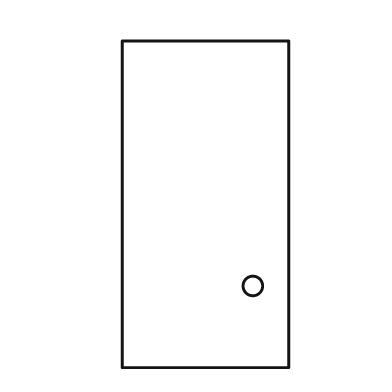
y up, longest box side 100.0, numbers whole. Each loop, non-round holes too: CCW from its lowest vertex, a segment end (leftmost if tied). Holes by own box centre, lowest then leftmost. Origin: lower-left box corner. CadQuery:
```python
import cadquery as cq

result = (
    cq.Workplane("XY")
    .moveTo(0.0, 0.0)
    .lineTo(51.0, 0.0)
    .lineTo(51.0, 100.0)
    .lineTo(0.0, 100.0)
    .close()
    .moveTo(40.0, 25.0)
    .circle(3.0)
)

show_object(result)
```